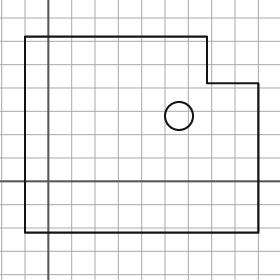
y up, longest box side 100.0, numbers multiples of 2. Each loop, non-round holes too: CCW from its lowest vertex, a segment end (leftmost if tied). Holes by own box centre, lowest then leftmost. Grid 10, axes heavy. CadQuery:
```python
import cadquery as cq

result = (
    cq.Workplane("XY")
    .moveTo(-10.0, -22.0)
    .lineTo(90.0, -22.0)
    .lineTo(90.0, 42.0)
    .lineTo(68.0, 42.0)
    .lineTo(68.0, 62.0)
    .lineTo(-10.0, 62.0)
    .close()
    .moveTo(56.0, 28.0)
    .circle(6.0)
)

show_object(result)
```